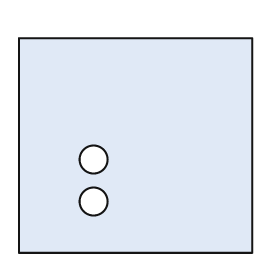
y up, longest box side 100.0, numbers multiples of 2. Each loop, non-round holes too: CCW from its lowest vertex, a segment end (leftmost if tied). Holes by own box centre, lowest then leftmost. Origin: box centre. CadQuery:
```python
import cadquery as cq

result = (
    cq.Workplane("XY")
    .moveTo(-50.0, -46.0)
    .lineTo(50.0, -46.0)
    .lineTo(50.0, 46.0)
    .lineTo(-50.0, 46.0)
    .close()
    .moveTo(-18.0, -24.0)
    .circle(6.0)
    .moveTo(-18.0, -6.0)
    .circle(6.0)
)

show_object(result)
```